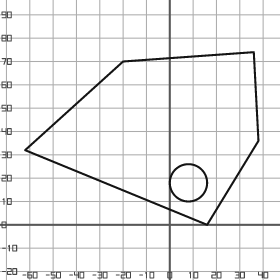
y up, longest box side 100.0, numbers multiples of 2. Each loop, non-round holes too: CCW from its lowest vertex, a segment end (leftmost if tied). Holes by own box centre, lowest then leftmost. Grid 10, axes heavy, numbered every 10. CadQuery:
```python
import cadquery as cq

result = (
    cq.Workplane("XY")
    .moveTo(16.0, 0.0)
    .lineTo(38.0, 36.0)
    .lineTo(36.0, 74.0)
    .lineTo(-20.0, 70.0)
    .lineTo(-62.0, 32.0)
    .close()
    .moveTo(8.0, 18.0)
    .circle(8.0)
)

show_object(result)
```